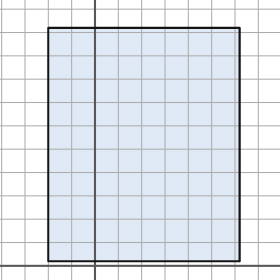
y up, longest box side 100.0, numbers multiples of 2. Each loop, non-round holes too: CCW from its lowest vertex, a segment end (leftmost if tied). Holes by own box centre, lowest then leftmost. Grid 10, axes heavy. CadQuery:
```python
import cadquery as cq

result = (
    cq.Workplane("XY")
    .moveTo(-20.0, 2.0)
    .lineTo(62.0, 2.0)
    .lineTo(62.0, 102.0)
    .lineTo(-20.0, 102.0)
    .close()
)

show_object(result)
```